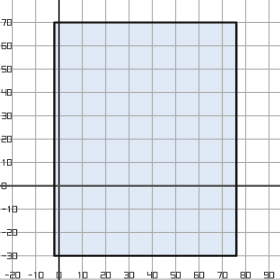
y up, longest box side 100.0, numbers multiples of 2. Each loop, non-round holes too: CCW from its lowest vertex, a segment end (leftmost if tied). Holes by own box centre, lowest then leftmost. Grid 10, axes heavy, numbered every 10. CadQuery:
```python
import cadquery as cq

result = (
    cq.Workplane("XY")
    .moveTo(-2.0, -30.0)
    .lineTo(76.0, -30.0)
    .lineTo(76.0, 70.0)
    .lineTo(-2.0, 70.0)
    .close()
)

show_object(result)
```